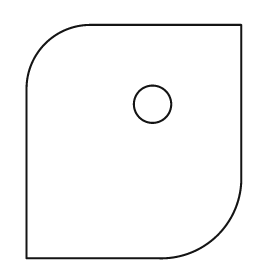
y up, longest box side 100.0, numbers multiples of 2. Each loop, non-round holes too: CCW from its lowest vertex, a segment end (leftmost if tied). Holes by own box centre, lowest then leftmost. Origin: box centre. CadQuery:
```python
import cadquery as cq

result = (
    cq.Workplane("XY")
    .moveTo(-46.0, -50.0)
    .lineTo(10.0, -50.0)
    .threePointArc((36.0, -40.0), (46.0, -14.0))
    .lineTo(46.0, 50.0)
    .lineTo(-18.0, 50.0)
    .threePointArc((-38.0, 42.0), (-46.0, 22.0))
    .close()
    .moveTo(8.0, 16.0)
    .circle(8.0)
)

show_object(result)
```